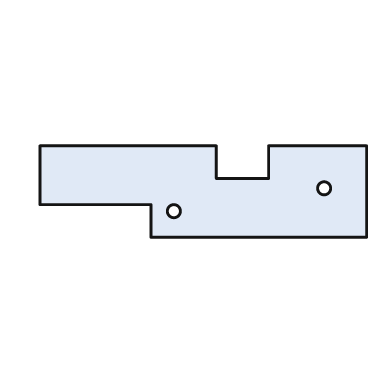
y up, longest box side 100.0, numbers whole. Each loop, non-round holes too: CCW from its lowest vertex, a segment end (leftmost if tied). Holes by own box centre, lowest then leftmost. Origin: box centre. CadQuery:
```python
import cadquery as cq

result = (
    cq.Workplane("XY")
    .moveTo(-16.0, -14.0)
    .lineTo(50.0, -14.0)
    .lineTo(50.0, 14.0)
    .lineTo(20.0, 14.0)
    .lineTo(20.0, 4.0)
    .lineTo(4.0, 4.0)
    .lineTo(4.0, 14.0)
    .lineTo(-50.0, 14.0)
    .lineTo(-50.0, -4.0)
    .lineTo(-16.0, -4.0)
    .close()
    .moveTo(-9.0, -6.0)
    .circle(2.0)
    .moveTo(37.0, 1.0)
    .circle(2.0)
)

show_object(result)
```